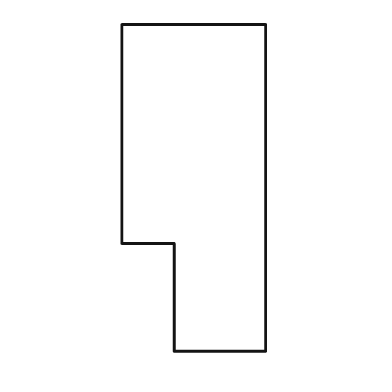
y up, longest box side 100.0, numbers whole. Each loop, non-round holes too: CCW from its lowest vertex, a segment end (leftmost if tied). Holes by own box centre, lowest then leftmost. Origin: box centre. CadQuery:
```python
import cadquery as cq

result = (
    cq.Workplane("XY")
    .moveTo(-6.0, -50.0)
    .lineTo(22.0, -50.0)
    .lineTo(22.0, 50.0)
    .lineTo(-22.0, 50.0)
    .lineTo(-22.0, -17.0)
    .lineTo(-6.0, -17.0)
    .close()
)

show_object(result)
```